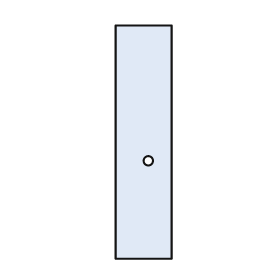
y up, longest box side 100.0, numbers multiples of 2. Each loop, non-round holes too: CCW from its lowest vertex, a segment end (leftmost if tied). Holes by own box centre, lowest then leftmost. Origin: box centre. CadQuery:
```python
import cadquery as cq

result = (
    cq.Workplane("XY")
    .moveTo(-12.0, -50.0)
    .lineTo(12.0, -50.0)
    .lineTo(12.0, 50.0)
    .lineTo(-12.0, 50.0)
    .close()
    .moveTo(2.0, -8.0)
    .circle(2.0)
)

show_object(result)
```